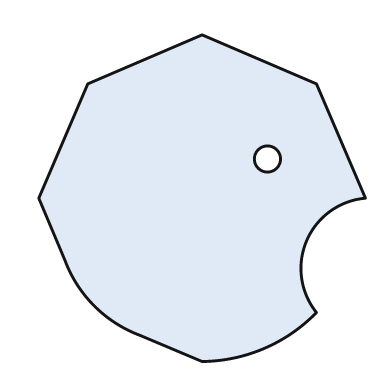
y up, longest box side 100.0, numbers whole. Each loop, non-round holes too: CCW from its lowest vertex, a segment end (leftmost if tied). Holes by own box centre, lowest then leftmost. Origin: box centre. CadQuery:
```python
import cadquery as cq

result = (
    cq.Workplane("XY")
    .moveTo(0.0, -50.0)
    .threePointArc((19.0, -46.0), (35.0, -35.0))
    .threePointArc((32.0, -13.0), (50.0, 0.0))
    .lineTo(35.0, 35.0)
    .lineTo(0.0, 50.0)
    .lineTo(-35.0, 35.0)
    .lineTo(-50.0, 0.0)
    .lineTo(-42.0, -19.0)
    .threePointArc((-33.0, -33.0), (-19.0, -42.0))
    .close()
    .moveTo(20.0, 12.0)
    .circle(4.0)
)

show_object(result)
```